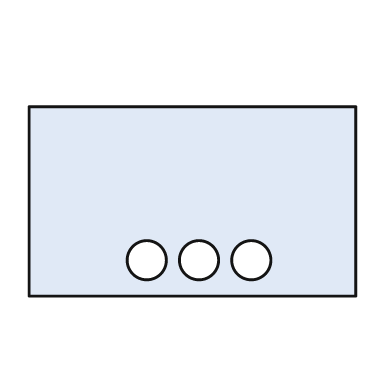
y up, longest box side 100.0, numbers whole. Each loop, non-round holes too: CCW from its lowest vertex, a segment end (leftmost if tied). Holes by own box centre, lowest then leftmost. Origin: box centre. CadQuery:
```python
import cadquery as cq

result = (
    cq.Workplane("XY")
    .moveTo(-50.0, -29.0)
    .lineTo(50.0, -29.0)
    .lineTo(50.0, 29.0)
    .lineTo(-50.0, 29.0)
    .close()
    .moveTo(-14.0, -18.0)
    .circle(6.0)
    .moveTo(2.0, -18.0)
    .circle(6.0)
    .moveTo(18.0, -18.0)
    .circle(6.0)
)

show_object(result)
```